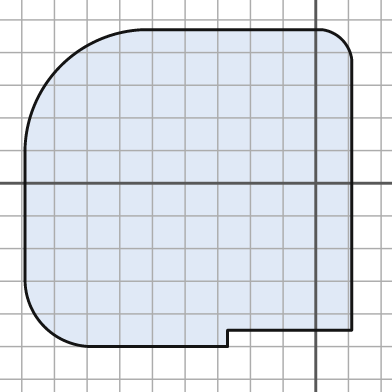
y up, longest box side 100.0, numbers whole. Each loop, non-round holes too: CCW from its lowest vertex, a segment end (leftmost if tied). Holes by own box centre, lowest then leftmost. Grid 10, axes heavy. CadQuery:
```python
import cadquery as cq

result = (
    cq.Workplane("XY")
    .moveTo(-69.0, -50.0)
    .lineTo(-27.0, -50.0)
    .lineTo(-27.0, -45.0)
    .lineTo(11.0, -45.0)
    .lineTo(11.0, 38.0)
    .threePointArc((8.0, 44.0), (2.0, 47.0))
    .lineTo(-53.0, 47.0)
    .threePointArc((-78.0, 36.0), (-89.0, 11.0))
    .lineTo(-89.0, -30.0)
    .threePointArc((-83.0, -44.0), (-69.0, -50.0))
    .close()
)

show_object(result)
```